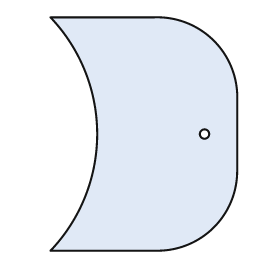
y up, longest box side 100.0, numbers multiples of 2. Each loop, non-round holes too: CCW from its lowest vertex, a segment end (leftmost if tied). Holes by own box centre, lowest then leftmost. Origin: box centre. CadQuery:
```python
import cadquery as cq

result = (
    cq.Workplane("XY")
    .moveTo(-40.0, -50.0)
    .lineTo(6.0, -50.0)
    .threePointArc((30.0, -40.0), (40.0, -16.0))
    .lineTo(40.0, 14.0)
    .threePointArc((30.0, 40.0), (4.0, 50.0))
    .lineTo(-40.0, 50.0)
    .threePointArc((-20.0, 0.0), (-40.0, -50.0))
    .close()
    .moveTo(26.0, 0.0)
    .circle(2.0)
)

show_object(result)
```